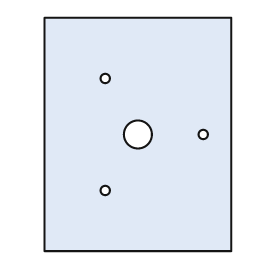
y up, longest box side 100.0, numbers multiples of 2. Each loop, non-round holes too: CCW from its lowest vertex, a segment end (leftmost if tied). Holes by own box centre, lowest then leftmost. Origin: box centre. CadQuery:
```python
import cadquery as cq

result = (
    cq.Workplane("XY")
    .moveTo(-40.0, -50.0)
    .lineTo(40.0, -50.0)
    .lineTo(40.0, 50.0)
    .lineTo(-40.0, 50.0)
    .close()
    .moveTo(-14.0, -24.0)
    .circle(2.0)
    .moveTo(0.0, 0.0)
    .circle(6.0)
    .moveTo(28.0, 0.0)
    .circle(2.0)
    .moveTo(-14.0, 24.0)
    .circle(2.0)
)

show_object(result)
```